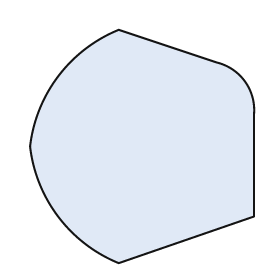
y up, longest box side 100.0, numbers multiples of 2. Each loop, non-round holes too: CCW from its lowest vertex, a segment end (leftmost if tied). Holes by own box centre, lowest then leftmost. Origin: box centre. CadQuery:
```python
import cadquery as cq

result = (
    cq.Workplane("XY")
    .moveTo(-10.0, -50.0)
    .lineTo(48.0, -30.0)
    .lineTo(48.0, 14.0)
    .threePointArc((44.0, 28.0), (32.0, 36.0))
    .lineTo(-10.0, 50.0)
    .threePointArc((-36.0, 30.0), (-48.0, 0.0))
    .threePointArc((-36.0, -30.0), (-10.0, -50.0))
    .close()
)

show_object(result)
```